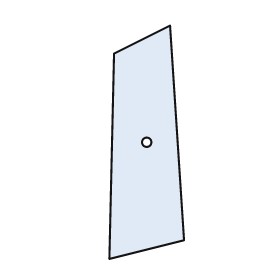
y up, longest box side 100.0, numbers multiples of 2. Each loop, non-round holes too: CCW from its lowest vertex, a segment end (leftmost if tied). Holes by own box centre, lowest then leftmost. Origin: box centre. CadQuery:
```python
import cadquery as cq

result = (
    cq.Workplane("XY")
    .moveTo(-16.0, -50.0)
    .lineTo(16.0, -42.0)
    .lineTo(10.0, 50.0)
    .lineTo(-14.0, 38.0)
    .close()
    .moveTo(0.0, 0.0)
    .circle(2.0)
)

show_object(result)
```